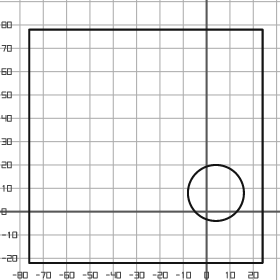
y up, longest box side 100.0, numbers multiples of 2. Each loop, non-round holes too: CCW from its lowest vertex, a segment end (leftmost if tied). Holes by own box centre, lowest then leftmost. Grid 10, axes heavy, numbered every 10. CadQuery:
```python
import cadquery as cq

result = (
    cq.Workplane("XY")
    .moveTo(-76.0, -22.0)
    .lineTo(24.0, -22.0)
    .lineTo(24.0, 78.0)
    .lineTo(-76.0, 78.0)
    .close()
    .moveTo(4.0, 8.0)
    .circle(12.0)
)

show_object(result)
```